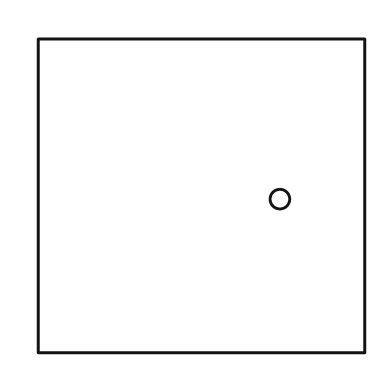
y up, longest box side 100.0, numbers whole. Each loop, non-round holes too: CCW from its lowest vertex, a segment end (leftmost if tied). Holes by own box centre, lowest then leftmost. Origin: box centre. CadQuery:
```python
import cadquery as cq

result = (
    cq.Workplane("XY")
    .moveTo(-50.0, -48.0)
    .lineTo(50.0, -48.0)
    .lineTo(50.0, 48.0)
    .lineTo(-50.0, 48.0)
    .close()
    .moveTo(24.0, -1.0)
    .circle(3.0)
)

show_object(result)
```